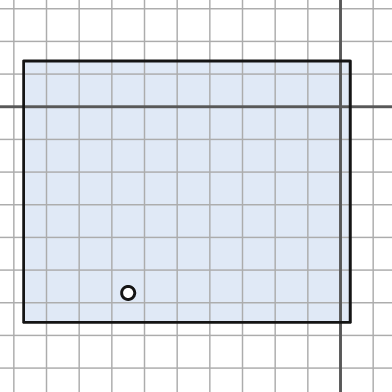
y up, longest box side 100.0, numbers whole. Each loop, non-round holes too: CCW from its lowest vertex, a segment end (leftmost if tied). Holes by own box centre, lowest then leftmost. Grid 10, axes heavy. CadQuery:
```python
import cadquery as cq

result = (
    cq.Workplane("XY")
    .moveTo(-97.0, -66.0)
    .lineTo(3.0, -66.0)
    .lineTo(3.0, 14.0)
    .lineTo(-97.0, 14.0)
    .close()
    .moveTo(-65.0, -57.0)
    .circle(2.0)
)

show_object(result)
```